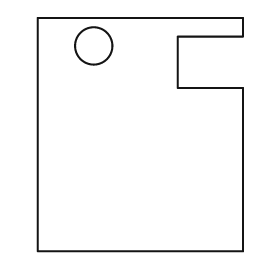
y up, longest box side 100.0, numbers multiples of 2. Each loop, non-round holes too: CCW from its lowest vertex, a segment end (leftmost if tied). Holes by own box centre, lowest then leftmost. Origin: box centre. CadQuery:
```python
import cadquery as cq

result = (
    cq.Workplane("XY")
    .moveTo(-44.0, -50.0)
    .lineTo(44.0, -50.0)
    .lineTo(44.0, 20.0)
    .lineTo(16.0, 20.0)
    .lineTo(16.0, 42.0)
    .lineTo(44.0, 42.0)
    .lineTo(44.0, 50.0)
    .lineTo(-44.0, 50.0)
    .close()
    .moveTo(-20.0, 38.0)
    .circle(8.0)
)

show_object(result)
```